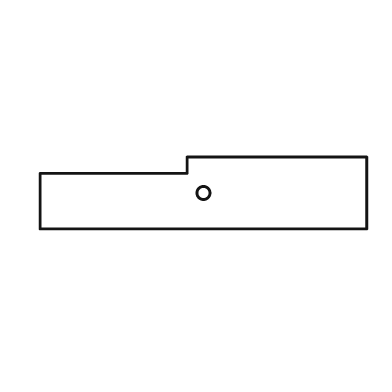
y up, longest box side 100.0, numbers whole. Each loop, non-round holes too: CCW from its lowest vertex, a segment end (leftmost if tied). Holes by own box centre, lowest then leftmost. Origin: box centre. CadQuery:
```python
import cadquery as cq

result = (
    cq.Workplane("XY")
    .moveTo(-50.0, -11.0)
    .lineTo(50.0, -11.0)
    .lineTo(50.0, 11.0)
    .lineTo(-5.0, 11.0)
    .lineTo(-5.0, 6.0)
    .lineTo(-50.0, 6.0)
    .close()
    .moveTo(0.0, 0.0)
    .circle(2.0)
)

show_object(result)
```